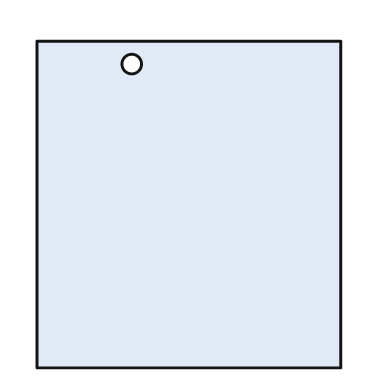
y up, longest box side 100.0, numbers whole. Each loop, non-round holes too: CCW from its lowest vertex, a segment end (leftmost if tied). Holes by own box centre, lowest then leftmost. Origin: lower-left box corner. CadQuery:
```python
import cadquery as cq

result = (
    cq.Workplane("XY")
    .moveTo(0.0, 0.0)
    .lineTo(93.0, 0.0)
    .lineTo(93.0, 100.0)
    .lineTo(0.0, 100.0)
    .close()
    .moveTo(29.0, 93.0)
    .circle(3.0)
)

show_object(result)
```